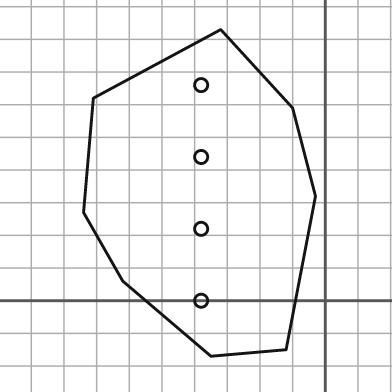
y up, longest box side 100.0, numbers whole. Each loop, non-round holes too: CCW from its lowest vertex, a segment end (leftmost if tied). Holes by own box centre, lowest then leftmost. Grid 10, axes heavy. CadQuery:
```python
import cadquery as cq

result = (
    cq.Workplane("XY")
    .moveTo(-35.0, -17.0)
    .lineTo(-12.0, -15.0)
    .lineTo(-3.0, 32.0)
    .lineTo(-10.0, 59.0)
    .lineTo(-32.0, 83.0)
    .lineTo(-71.0, 62.0)
    .lineTo(-74.0, 27.0)
    .lineTo(-62.0, 6.0)
    .close()
    .moveTo(-38.0, 0.0)
    .circle(2.0)
    .moveTo(-38.0, 22.0)
    .circle(2.0)
    .moveTo(-38.0, 44.0)
    .circle(2.0)
    .moveTo(-38.0, 66.0)
    .circle(2.0)
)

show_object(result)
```